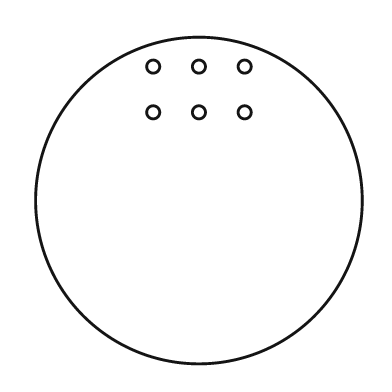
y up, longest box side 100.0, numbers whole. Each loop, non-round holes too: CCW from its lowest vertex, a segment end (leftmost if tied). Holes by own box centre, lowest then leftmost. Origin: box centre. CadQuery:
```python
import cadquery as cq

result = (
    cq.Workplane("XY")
    .moveTo(0.0, 0.0)
    .circle(50.0)
    .moveTo(-14.0, 27.0)
    .circle(2.0)
    .moveTo(0.0, 27.0)
    .circle(2.0)
    .moveTo(14.0, 27.0)
    .circle(2.0)
    .moveTo(-14.0, 41.0)
    .circle(2.0)
    .moveTo(0.0, 41.0)
    .circle(2.0)
    .moveTo(14.0, 41.0)
    .circle(2.0)
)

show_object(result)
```